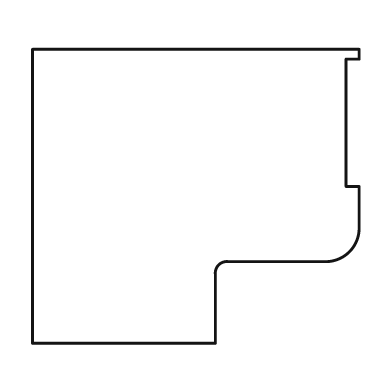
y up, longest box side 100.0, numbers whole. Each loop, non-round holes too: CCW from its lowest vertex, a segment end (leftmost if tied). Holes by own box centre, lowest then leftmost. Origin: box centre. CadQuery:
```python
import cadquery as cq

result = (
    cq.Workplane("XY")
    .moveTo(-50.0, -45.0)
    .lineTo(6.0, -45.0)
    .lineTo(6.0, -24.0)
    .threePointArc((7.0, -21.0), (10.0, -20.0))
    .lineTo(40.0, -20.0)
    .threePointArc((47.0, -17.0), (50.0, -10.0))
    .lineTo(50.0, 3.0)
    .lineTo(46.0, 3.0)
    .lineTo(46.0, 42.0)
    .lineTo(50.0, 42.0)
    .lineTo(50.0, 45.0)
    .lineTo(-50.0, 45.0)
    .close()
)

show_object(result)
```